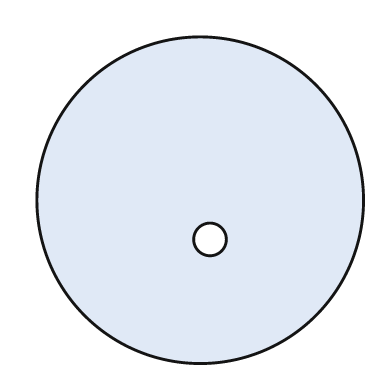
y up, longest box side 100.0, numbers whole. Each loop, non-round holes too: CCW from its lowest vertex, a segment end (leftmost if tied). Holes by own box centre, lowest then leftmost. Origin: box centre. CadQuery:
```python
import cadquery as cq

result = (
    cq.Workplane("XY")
    .moveTo(0.0, 0.0)
    .circle(50.0)
    .moveTo(3.0, -12.0)
    .circle(5.0)
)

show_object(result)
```